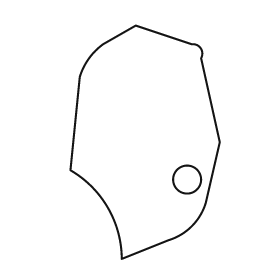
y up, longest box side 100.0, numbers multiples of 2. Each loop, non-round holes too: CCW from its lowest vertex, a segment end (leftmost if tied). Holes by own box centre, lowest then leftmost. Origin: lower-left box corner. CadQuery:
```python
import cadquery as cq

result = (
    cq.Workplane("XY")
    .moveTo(22.0, 0.0)
    .lineTo(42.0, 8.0)
    .threePointArc((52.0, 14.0), (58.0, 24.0))
    .lineTo(64.0, 50.0)
    .lineTo(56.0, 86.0)
    .threePointArc((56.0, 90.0), (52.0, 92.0))
    .lineTo(28.0, 100.0)
    .lineTo(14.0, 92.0)
    .threePointArc((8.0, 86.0), (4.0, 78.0))
    .lineTo(0.0, 38.0)
    .threePointArc((16.0, 22.0), (22.0, 0.0))
    .close()
    .moveTo(50.0, 34.0)
    .circle(6.0)
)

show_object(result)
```